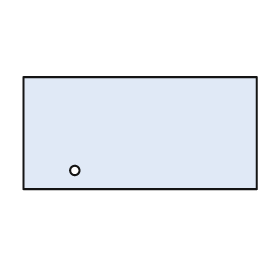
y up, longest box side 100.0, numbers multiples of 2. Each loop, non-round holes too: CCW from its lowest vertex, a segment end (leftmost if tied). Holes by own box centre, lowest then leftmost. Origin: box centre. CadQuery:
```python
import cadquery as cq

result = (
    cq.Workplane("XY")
    .moveTo(-50.0, -24.0)
    .lineTo(50.0, -24.0)
    .lineTo(50.0, 24.0)
    .lineTo(-50.0, 24.0)
    .close()
    .moveTo(-28.0, -16.0)
    .circle(2.0)
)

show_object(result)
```